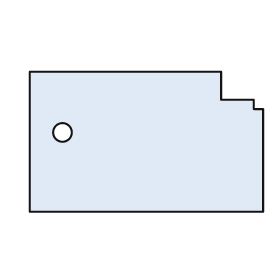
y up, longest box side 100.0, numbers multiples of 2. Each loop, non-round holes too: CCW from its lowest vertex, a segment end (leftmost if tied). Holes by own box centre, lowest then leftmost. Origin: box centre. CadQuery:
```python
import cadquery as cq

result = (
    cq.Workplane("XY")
    .moveTo(-50.0, -30.0)
    .lineTo(50.0, -30.0)
    .lineTo(50.0, 14.0)
    .lineTo(46.0, 14.0)
    .lineTo(46.0, 18.0)
    .lineTo(32.0, 18.0)
    .lineTo(32.0, 30.0)
    .lineTo(-50.0, 30.0)
    .close()
    .moveTo(-36.0, 4.0)
    .circle(4.0)
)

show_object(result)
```